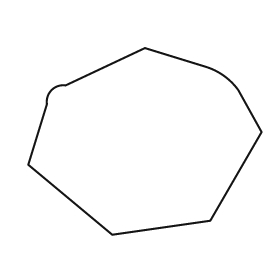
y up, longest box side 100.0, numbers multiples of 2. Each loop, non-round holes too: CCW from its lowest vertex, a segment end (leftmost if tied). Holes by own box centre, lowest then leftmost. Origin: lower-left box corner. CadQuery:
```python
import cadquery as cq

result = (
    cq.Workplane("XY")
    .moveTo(36.0, 0.0)
    .lineTo(78.0, 6.0)
    .lineTo(100.0, 44.0)
    .lineTo(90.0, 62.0)
    .threePointArc((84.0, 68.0), (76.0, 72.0))
    .lineTo(50.0, 80.0)
    .lineTo(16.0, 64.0)
    .threePointArc((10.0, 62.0), (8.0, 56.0))
    .lineTo(0.0, 30.0)
    .close()
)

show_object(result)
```